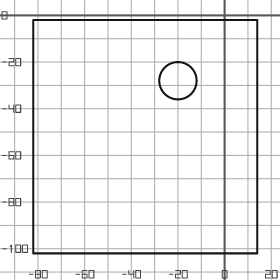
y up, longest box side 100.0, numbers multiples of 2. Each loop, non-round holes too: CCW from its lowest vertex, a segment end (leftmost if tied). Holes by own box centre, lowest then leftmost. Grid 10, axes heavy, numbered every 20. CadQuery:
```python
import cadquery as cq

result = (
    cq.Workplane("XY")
    .moveTo(-82.0, -102.0)
    .lineTo(14.0, -102.0)
    .lineTo(14.0, -2.0)
    .lineTo(-82.0, -2.0)
    .close()
    .moveTo(-20.0, -28.0)
    .circle(8.0)
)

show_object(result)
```